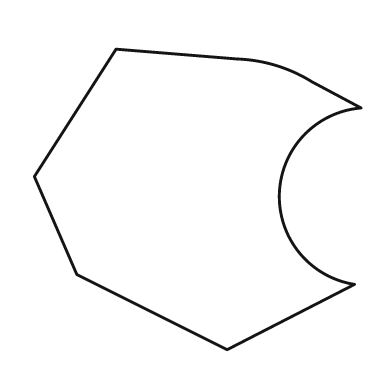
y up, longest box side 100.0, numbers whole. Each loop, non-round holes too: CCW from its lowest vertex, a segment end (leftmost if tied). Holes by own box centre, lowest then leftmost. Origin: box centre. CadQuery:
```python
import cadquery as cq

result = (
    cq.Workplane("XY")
    .moveTo(9.0, -46.0)
    .lineTo(48.0, -26.0)
    .threePointArc((25.0, 2.0), (50.0, 28.0))
    .lineTo(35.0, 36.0)
    .threePointArc((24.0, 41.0), (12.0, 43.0))
    .lineTo(-25.0, 46.0)
    .lineTo(-50.0, 7.0)
    .lineTo(-37.0, -23.0)
    .close()
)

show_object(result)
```